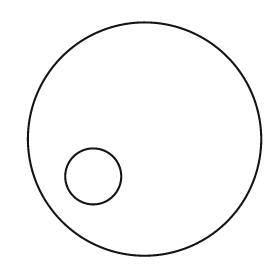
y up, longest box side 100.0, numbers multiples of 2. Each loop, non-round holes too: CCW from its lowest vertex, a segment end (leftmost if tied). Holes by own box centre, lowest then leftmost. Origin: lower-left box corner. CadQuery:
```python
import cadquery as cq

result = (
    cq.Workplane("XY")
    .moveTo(50.0, 50.0)
    .circle(50.0)
    .moveTo(28.0, 34.0)
    .circle(12.0)
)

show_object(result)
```